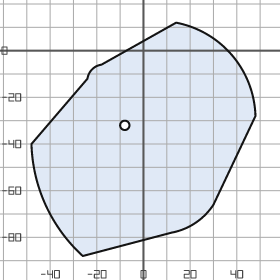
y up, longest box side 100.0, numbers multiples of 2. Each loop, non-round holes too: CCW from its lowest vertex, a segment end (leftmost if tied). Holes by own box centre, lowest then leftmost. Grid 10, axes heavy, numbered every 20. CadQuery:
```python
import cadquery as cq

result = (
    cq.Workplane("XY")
    .moveTo(-26.0, -88.0)
    .lineTo(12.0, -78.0)
    .threePointArc((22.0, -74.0), (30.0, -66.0))
    .lineTo(48.0, -28.0)
    .threePointArc((38.0, -2.0), (14.0, 12.0))
    .lineTo(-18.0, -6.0)
    .threePointArc((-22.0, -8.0), (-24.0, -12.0))
    .lineTo(-48.0, -40.0)
    .threePointArc((-42.0, -66.0), (-26.0, -88.0))
    .close()
    .moveTo(-8.0, -32.0)
    .circle(2.0)
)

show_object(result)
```